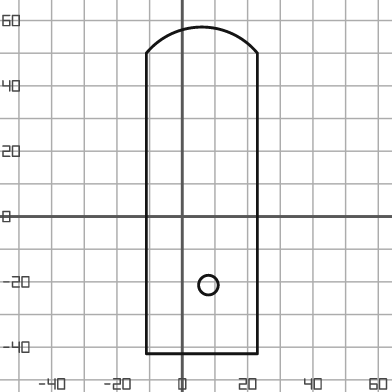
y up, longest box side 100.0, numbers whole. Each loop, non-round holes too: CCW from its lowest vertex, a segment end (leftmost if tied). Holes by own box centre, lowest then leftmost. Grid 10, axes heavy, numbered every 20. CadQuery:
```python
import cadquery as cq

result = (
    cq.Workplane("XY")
    .moveTo(-11.0, -42.0)
    .lineTo(23.0, -42.0)
    .lineTo(23.0, 50.0)
    .threePointArc((6.0, 58.0), (-11.0, 50.0))
    .close()
    .moveTo(8.0, -21.0)
    .circle(3.0)
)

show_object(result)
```